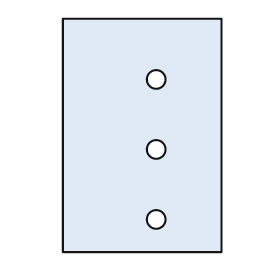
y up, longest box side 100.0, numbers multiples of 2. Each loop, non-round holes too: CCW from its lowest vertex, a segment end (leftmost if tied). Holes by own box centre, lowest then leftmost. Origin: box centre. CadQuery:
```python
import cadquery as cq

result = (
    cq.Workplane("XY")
    .moveTo(-34.0, -50.0)
    .lineTo(34.0, -50.0)
    .lineTo(34.0, 50.0)
    .lineTo(-34.0, 50.0)
    .close()
    .moveTo(6.0, -36.0)
    .circle(4.0)
    .moveTo(6.0, -6.0)
    .circle(4.0)
    .moveTo(6.0, 24.0)
    .circle(4.0)
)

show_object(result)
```